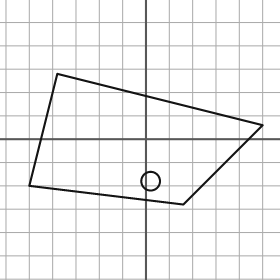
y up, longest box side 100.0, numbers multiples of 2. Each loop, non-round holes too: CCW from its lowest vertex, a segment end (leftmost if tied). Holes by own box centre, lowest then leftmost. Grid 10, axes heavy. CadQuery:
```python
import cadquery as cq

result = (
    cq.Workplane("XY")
    .moveTo(16.0, -28.0)
    .lineTo(50.0, 6.0)
    .lineTo(-38.0, 28.0)
    .lineTo(-50.0, -20.0)
    .close()
    .moveTo(2.0, -18.0)
    .circle(4.0)
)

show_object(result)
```